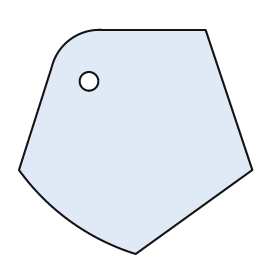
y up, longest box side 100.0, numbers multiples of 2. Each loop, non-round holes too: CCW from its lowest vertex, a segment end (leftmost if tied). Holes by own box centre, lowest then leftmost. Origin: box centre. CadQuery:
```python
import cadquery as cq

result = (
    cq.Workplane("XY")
    .moveTo(0.0, -48.0)
    .lineTo(50.0, -12.0)
    .lineTo(30.0, 48.0)
    .lineTo(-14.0, 48.0)
    .threePointArc((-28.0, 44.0), (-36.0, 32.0))
    .lineTo(-50.0, -12.0)
    .threePointArc((-28.0, -34.0), (0.0, -48.0))
    .close()
    .moveTo(-20.0, 26.0)
    .circle(4.0)
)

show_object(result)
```